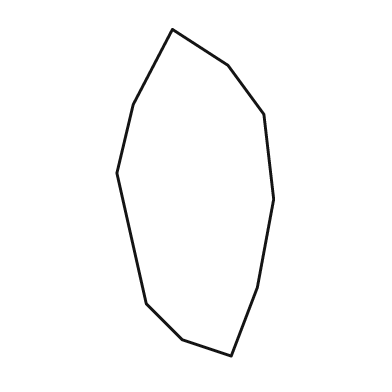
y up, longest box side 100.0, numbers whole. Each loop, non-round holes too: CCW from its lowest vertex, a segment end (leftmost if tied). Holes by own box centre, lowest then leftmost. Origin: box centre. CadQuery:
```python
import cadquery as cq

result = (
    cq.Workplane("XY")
    .moveTo(11.0, -50.0)
    .lineTo(19.0, -29.0)
    .lineTo(24.0, -2.0)
    .lineTo(21.0, 24.0)
    .lineTo(10.0, 39.0)
    .lineTo(-7.0, 50.0)
    .lineTo(-19.0, 27.0)
    .lineTo(-24.0, 6.0)
    .lineTo(-15.0, -34.0)
    .lineTo(-4.0, -45.0)
    .close()
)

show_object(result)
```